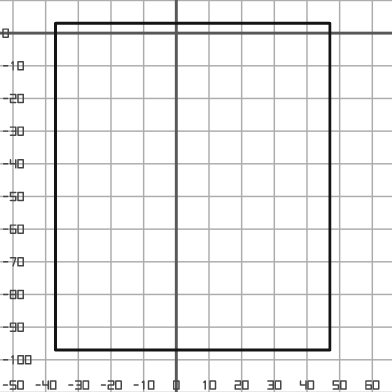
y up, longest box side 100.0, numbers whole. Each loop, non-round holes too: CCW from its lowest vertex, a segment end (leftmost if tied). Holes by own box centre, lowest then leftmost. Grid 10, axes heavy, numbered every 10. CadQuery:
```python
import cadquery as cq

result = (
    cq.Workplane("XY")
    .moveTo(-37.0, -97.0)
    .lineTo(47.0, -97.0)
    .lineTo(47.0, 3.0)
    .lineTo(-37.0, 3.0)
    .close()
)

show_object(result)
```